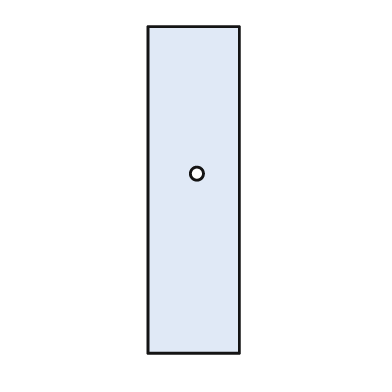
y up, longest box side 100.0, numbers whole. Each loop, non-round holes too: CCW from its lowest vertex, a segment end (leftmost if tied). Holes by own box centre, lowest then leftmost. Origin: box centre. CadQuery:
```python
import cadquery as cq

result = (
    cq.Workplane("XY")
    .moveTo(-14.0, -50.0)
    .lineTo(14.0, -50.0)
    .lineTo(14.0, 50.0)
    .lineTo(-14.0, 50.0)
    .close()
    .moveTo(1.0, 5.0)
    .circle(2.0)
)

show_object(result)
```